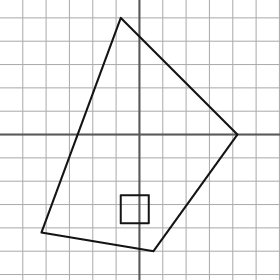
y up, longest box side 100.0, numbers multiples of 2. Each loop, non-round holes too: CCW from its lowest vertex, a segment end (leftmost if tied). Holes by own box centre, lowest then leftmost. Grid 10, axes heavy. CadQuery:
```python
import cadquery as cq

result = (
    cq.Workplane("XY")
    .moveTo(6.0, -50.0)
    .lineTo(42.0, 0.0)
    .lineTo(-8.0, 50.0)
    .lineTo(-42.0, -42.0)
    .close()
    .moveTo(-8.0, -38.0)
    .lineTo(4.0, -38.0)
    .lineTo(4.0, -26.0)
    .lineTo(-8.0, -26.0)
    .close()
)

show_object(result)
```